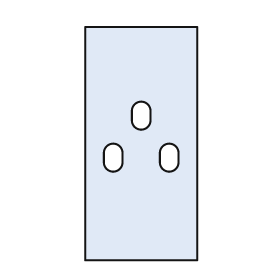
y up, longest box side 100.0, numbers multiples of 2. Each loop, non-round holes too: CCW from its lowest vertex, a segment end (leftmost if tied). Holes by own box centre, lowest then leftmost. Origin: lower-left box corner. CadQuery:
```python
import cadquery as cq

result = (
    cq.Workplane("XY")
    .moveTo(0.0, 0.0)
    .lineTo(48.0, 0.0)
    .lineTo(48.0, 100.0)
    .lineTo(0.0, 100.0)
    .close()
    .moveTo(8.0, 42.0)
    .threePointArc((12.0, 38.0), (16.0, 42.0))
    .lineTo(16.0, 46.0)
    .threePointArc((12.0, 50.0), (8.0, 46.0))
    .close()
    .moveTo(32.0, 42.0)
    .threePointArc((36.0, 38.0), (40.0, 42.0))
    .lineTo(40.0, 46.0)
    .threePointArc((36.0, 50.0), (32.0, 46.0))
    .close()
    .moveTo(20.0, 60.0)
    .threePointArc((24.0, 56.0), (28.0, 60.0))
    .lineTo(28.0, 64.0)
    .threePointArc((24.0, 68.0), (20.0, 64.0))
    .close()
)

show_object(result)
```